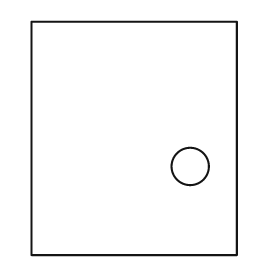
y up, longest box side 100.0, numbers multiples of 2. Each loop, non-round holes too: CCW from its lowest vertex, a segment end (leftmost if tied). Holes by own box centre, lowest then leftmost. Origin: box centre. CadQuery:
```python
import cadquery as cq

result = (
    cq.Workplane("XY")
    .moveTo(-44.0, -50.0)
    .lineTo(44.0, -50.0)
    .lineTo(44.0, 50.0)
    .lineTo(-44.0, 50.0)
    .close()
    .moveTo(24.0, -12.0)
    .circle(8.0)
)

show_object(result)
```